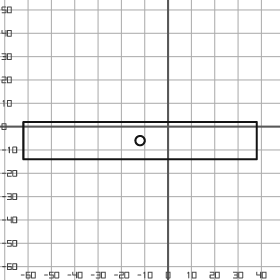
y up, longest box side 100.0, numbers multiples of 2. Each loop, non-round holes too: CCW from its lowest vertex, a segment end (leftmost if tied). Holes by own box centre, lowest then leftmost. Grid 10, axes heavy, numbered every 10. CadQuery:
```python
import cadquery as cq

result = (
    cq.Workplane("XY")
    .moveTo(-62.0, -14.0)
    .lineTo(38.0, -14.0)
    .lineTo(38.0, 2.0)
    .lineTo(-62.0, 2.0)
    .close()
    .moveTo(-12.0, -6.0)
    .circle(2.0)
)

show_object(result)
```